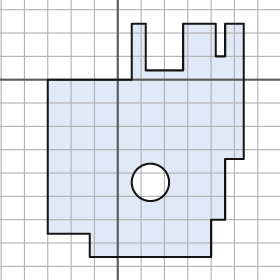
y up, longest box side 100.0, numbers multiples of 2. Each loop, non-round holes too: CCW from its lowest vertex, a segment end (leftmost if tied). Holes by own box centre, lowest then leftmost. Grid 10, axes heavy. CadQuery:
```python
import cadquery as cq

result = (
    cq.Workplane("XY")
    .moveTo(-12.0, -76.0)
    .lineTo(40.0, -76.0)
    .lineTo(40.0, -60.0)
    .lineTo(46.0, -60.0)
    .lineTo(46.0, -34.0)
    .lineTo(54.0, -34.0)
    .lineTo(54.0, 24.0)
    .lineTo(46.0, 24.0)
    .lineTo(46.0, 10.0)
    .lineTo(42.0, 10.0)
    .lineTo(42.0, 24.0)
    .lineTo(28.0, 24.0)
    .lineTo(28.0, 4.0)
    .lineTo(12.0, 4.0)
    .lineTo(12.0, 24.0)
    .lineTo(6.0, 24.0)
    .lineTo(6.0, 0.0)
    .lineTo(-30.0, 0.0)
    .lineTo(-30.0, -66.0)
    .lineTo(-12.0, -66.0)
    .close()
    .moveTo(14.0, -44.0)
    .circle(8.0)
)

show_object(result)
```